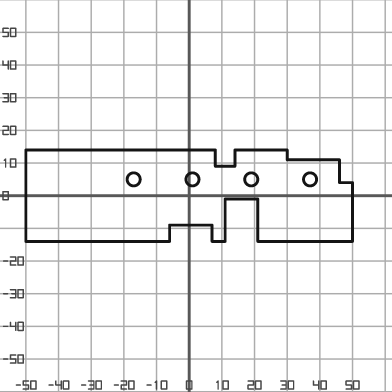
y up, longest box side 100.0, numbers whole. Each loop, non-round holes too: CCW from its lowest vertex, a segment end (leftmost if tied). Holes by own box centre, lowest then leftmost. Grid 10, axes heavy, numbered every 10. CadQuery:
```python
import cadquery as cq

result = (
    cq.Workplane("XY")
    .moveTo(-50.0, -14.0)
    .lineTo(-6.0, -14.0)
    .lineTo(-6.0, -9.0)
    .lineTo(7.0, -9.0)
    .lineTo(7.0, -14.0)
    .lineTo(11.0, -14.0)
    .lineTo(11.0, -1.0)
    .lineTo(21.0, -1.0)
    .lineTo(21.0, -14.0)
    .lineTo(50.0, -14.0)
    .lineTo(50.0, 4.0)
    .lineTo(46.0, 4.0)
    .lineTo(46.0, 11.0)
    .lineTo(30.0, 11.0)
    .lineTo(30.0, 14.0)
    .lineTo(14.0, 14.0)
    .lineTo(14.0, 9.0)
    .lineTo(8.0, 9.0)
    .lineTo(8.0, 14.0)
    .lineTo(-50.0, 14.0)
    .close()
    .moveTo(-17.0, 5.0)
    .circle(2.0)
    .moveTo(1.0, 5.0)
    .circle(2.0)
    .moveTo(19.0, 5.0)
    .circle(2.0)
    .moveTo(37.0, 5.0)
    .circle(2.0)
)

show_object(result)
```